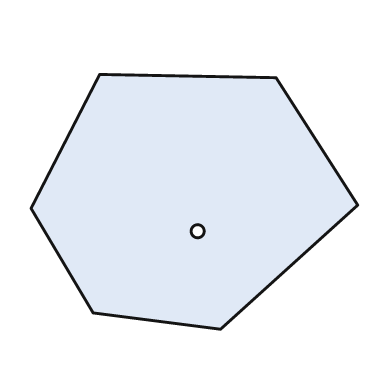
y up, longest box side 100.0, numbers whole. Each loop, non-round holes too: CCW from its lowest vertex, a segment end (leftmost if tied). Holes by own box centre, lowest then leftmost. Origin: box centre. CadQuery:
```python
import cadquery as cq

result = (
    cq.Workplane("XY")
    .moveTo(8.0, -39.0)
    .lineTo(50.0, -1.0)
    .lineTo(25.0, 38.0)
    .lineTo(-29.0, 39.0)
    .lineTo(-50.0, -2.0)
    .lineTo(-31.0, -34.0)
    .close()
    .moveTo(1.0, -9.0)
    .circle(2.0)
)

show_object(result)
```